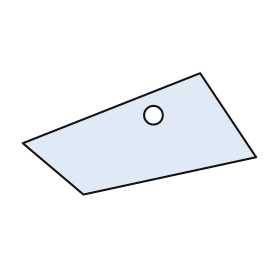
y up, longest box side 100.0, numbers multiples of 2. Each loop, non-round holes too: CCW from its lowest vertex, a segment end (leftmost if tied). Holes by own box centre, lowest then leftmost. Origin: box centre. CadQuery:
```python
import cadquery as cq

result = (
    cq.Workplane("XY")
    .moveTo(-24.0, -26.0)
    .lineTo(50.0, -10.0)
    .lineTo(26.0, 26.0)
    .lineTo(-50.0, -4.0)
    .close()
    .moveTo(6.0, 8.0)
    .circle(4.0)
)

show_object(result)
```